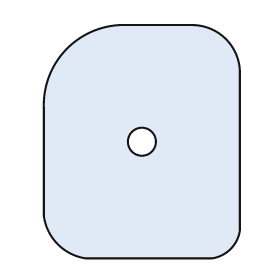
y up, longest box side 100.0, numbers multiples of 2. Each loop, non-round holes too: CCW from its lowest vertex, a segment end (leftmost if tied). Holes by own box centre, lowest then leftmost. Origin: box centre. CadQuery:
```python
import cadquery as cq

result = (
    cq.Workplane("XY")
    .moveTo(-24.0, -50.0)
    .lineTo(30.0, -50.0)
    .threePointArc((38.0, -46.0), (42.0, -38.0))
    .lineTo(42.0, 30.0)
    .threePointArc((36.0, 44.0), (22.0, 50.0))
    .lineTo(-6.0, 50.0)
    .threePointArc((-32.0, 40.0), (-42.0, 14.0))
    .lineTo(-42.0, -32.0)
    .threePointArc((-36.0, -44.0), (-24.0, -50.0))
    .close()
    .moveTo(0.0, 0.0)
    .circle(6.0)
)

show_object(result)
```